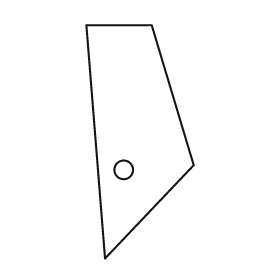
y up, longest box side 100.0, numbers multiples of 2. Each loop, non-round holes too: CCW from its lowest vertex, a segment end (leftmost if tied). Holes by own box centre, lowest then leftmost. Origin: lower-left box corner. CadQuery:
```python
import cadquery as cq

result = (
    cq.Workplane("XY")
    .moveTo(8.0, 0.0)
    .lineTo(46.0, 40.0)
    .lineTo(28.0, 100.0)
    .lineTo(0.0, 100.0)
    .close()
    .moveTo(16.0, 38.0)
    .circle(4.0)
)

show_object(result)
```